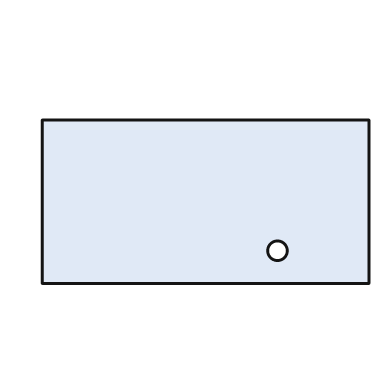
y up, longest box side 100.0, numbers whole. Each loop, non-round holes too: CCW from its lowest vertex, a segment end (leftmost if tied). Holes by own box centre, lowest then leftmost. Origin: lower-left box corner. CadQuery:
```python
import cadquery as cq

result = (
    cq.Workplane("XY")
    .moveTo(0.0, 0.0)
    .lineTo(100.0, 0.0)
    .lineTo(100.0, 50.0)
    .lineTo(0.0, 50.0)
    .close()
    .moveTo(72.0, 10.0)
    .circle(3.0)
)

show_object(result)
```